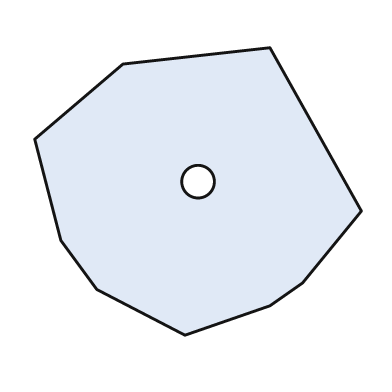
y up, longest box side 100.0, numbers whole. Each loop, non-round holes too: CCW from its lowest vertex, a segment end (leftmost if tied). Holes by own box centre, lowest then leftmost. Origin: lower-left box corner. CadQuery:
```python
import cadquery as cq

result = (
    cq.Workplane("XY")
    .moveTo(46.0, 0.0)
    .lineTo(72.0, 9.0)
    .lineTo(82.0, 16.0)
    .lineTo(100.0, 38.0)
    .lineTo(72.0, 88.0)
    .lineTo(27.0, 83.0)
    .lineTo(0.0, 60.0)
    .lineTo(8.0, 29.0)
    .lineTo(19.0, 14.0)
    .close()
    .moveTo(50.0, 47.0)
    .circle(5.0)
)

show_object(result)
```